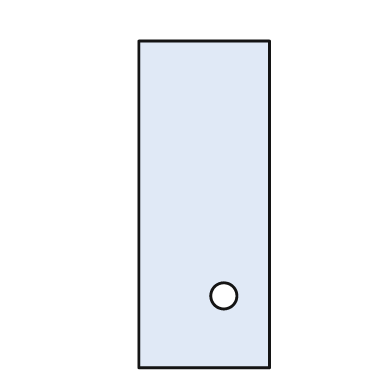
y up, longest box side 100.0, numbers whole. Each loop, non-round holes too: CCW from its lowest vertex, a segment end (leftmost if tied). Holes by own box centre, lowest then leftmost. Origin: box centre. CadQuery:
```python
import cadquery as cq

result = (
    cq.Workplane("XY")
    .moveTo(-20.0, -50.0)
    .lineTo(20.0, -50.0)
    .lineTo(20.0, 50.0)
    .lineTo(-20.0, 50.0)
    .close()
    .moveTo(6.0, -28.0)
    .circle(4.0)
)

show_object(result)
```